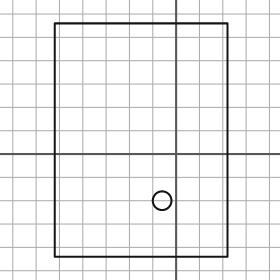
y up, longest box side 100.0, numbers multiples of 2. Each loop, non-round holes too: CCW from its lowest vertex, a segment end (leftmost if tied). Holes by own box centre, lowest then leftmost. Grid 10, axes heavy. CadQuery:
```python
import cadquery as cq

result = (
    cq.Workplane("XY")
    .moveTo(-52.0, -44.0)
    .lineTo(22.0, -44.0)
    .lineTo(22.0, 56.0)
    .lineTo(-52.0, 56.0)
    .close()
    .moveTo(-6.0, -20.0)
    .circle(4.0)
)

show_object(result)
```